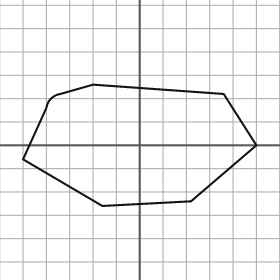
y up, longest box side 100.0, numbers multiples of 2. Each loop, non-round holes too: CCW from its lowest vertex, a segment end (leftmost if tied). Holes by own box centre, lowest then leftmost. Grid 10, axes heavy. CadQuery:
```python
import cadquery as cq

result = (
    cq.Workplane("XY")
    .moveTo(-16.0, -26.0)
    .lineTo(22.0, -24.0)
    .lineTo(50.0, 0.0)
    .lineTo(36.0, 22.0)
    .lineTo(-20.0, 26.0)
    .lineTo(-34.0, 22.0)
    .threePointArc((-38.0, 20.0), (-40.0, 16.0))
    .lineTo(-50.0, -6.0)
    .close()
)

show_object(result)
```